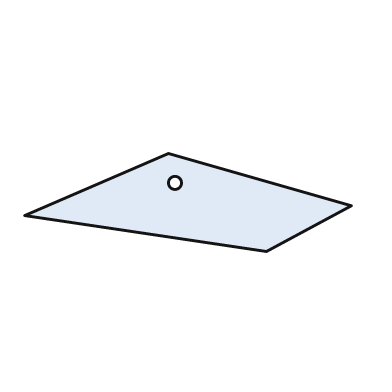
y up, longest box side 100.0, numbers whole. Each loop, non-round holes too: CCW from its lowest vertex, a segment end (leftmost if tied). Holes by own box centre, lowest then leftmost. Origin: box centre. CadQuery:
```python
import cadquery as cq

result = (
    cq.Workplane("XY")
    .moveTo(24.0, -15.0)
    .lineTo(50.0, -1.0)
    .lineTo(-6.0, 15.0)
    .lineTo(-50.0, -4.0)
    .close()
    .moveTo(-4.0, 6.0)
    .circle(2.0)
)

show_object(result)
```